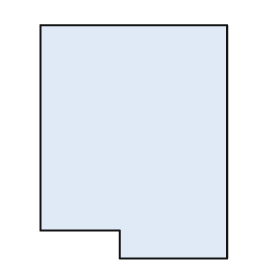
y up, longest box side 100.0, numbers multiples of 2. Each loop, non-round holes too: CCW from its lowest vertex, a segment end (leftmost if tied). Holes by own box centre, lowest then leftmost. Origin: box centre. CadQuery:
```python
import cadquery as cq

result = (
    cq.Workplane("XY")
    .moveTo(-6.0, -50.0)
    .lineTo(40.0, -50.0)
    .lineTo(40.0, 50.0)
    .lineTo(-40.0, 50.0)
    .lineTo(-40.0, -38.0)
    .lineTo(-6.0, -38.0)
    .close()
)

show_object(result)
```